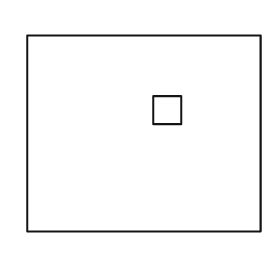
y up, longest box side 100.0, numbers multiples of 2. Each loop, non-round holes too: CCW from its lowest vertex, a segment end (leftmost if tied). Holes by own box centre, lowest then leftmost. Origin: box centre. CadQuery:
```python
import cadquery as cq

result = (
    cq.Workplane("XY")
    .moveTo(-50.0, -42.0)
    .lineTo(50.0, -42.0)
    .lineTo(50.0, 42.0)
    .lineTo(-50.0, 42.0)
    .close()
    .moveTo(4.0, 4.0)
    .lineTo(16.0, 4.0)
    .lineTo(16.0, 16.0)
    .lineTo(4.0, 16.0)
    .close()
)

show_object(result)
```